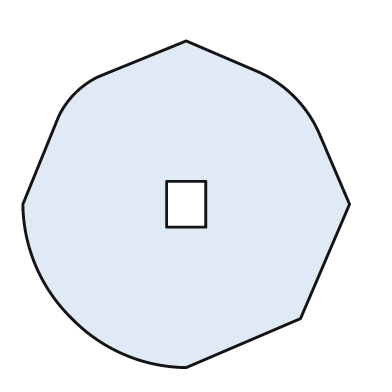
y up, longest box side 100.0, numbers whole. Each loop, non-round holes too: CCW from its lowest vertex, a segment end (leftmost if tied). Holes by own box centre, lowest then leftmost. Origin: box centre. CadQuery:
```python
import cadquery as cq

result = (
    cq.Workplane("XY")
    .moveTo(0.0, -50.0)
    .lineTo(35.0, -35.0)
    .lineTo(50.0, 0.0)
    .lineTo(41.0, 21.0)
    .threePointArc((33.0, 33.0), (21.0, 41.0))
    .lineTo(0.0, 50.0)
    .lineTo(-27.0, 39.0)
    .threePointArc((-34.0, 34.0), (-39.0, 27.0))
    .lineTo(-50.0, 0.0)
    .threePointArc((-46.0, -19.0), (-35.0, -35.0))
    .threePointArc((-19.0, -46.0), (0.0, -50.0))
    .close()
    .moveTo(-6.0, -7.0)
    .lineTo(6.0, -7.0)
    .lineTo(6.0, 7.0)
    .lineTo(-6.0, 7.0)
    .close()
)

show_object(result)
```